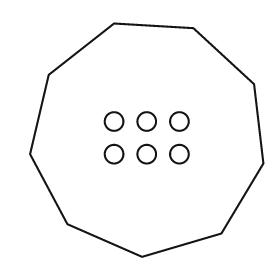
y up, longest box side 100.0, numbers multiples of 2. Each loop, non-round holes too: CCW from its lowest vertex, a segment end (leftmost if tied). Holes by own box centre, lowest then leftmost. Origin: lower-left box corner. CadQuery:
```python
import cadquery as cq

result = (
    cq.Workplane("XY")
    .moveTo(48.0, 0.0)
    .lineTo(82.0, 10.0)
    .lineTo(100.0, 40.0)
    .lineTo(96.0, 74.0)
    .lineTo(70.0, 98.0)
    .lineTo(36.0, 100.0)
    .lineTo(8.0, 78.0)
    .lineTo(0.0, 44.0)
    .lineTo(16.0, 14.0)
    .close()
    .moveTo(36.0, 44.0)
    .circle(4.0)
    .moveTo(50.0, 44.0)
    .circle(4.0)
    .moveTo(64.0, 44.0)
    .circle(4.0)
    .moveTo(36.0, 58.0)
    .circle(4.0)
    .moveTo(50.0, 58.0)
    .circle(4.0)
    .moveTo(64.0, 58.0)
    .circle(4.0)
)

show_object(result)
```